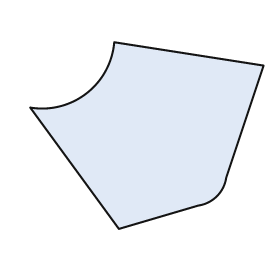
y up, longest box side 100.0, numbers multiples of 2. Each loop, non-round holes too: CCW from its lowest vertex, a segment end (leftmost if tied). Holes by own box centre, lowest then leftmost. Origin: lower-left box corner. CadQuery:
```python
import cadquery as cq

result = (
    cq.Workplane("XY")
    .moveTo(38.0, 0.0)
    .lineTo(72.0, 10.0)
    .threePointArc((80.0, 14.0), (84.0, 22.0))
    .lineTo(100.0, 70.0)
    .lineTo(36.0, 80.0)
    .threePointArc((24.0, 58.0), (0.0, 52.0))
    .close()
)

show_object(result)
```